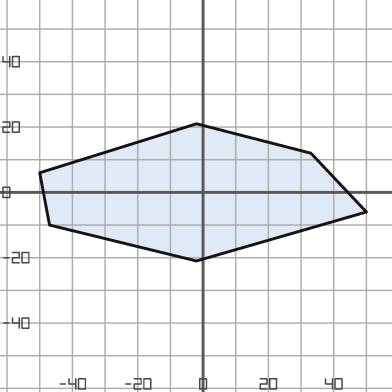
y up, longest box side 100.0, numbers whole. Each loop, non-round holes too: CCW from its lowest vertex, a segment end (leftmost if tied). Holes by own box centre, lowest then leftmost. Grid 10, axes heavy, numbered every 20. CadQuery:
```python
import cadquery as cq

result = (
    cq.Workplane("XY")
    .moveTo(-2.0, -21.0)
    .lineTo(50.0, -6.0)
    .lineTo(33.0, 12.0)
    .lineTo(-2.0, 21.0)
    .lineTo(-50.0, 6.0)
    .lineTo(-47.0, -10.0)
    .close()
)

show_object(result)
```